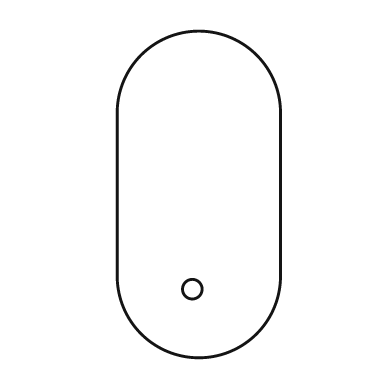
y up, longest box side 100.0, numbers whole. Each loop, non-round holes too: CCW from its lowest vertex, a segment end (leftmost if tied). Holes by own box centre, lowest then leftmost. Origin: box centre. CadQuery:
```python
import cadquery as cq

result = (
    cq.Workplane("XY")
    .moveTo(-25.0, -25.0)
    .threePointArc((0.0, -50.0), (25.0, -25.0))
    .lineTo(25.0, 25.0)
    .threePointArc((0.0, 50.0), (-25.0, 25.0))
    .close()
    .moveTo(-2.0, -29.0)
    .circle(3.0)
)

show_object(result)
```